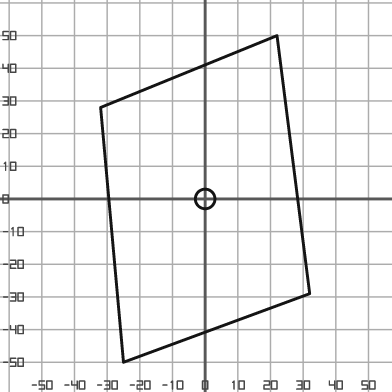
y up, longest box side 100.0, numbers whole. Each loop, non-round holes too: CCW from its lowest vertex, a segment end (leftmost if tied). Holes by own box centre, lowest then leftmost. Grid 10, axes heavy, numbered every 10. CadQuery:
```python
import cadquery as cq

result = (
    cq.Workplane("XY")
    .moveTo(-25.0, -50.0)
    .lineTo(32.0, -29.0)
    .lineTo(22.0, 50.0)
    .lineTo(-32.0, 28.0)
    .close()
    .moveTo(0.0, 0.0)
    .circle(3.0)
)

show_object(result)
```